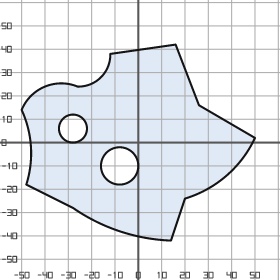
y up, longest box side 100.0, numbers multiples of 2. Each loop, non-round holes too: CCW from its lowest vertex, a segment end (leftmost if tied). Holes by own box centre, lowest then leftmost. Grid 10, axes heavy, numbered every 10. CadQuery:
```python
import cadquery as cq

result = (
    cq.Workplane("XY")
    .moveTo(14.0, -42.0)
    .lineTo(20.0, -24.0)
    .threePointArc((38.0, -14.0), (50.0, 2.0))
    .lineTo(26.0, 16.0)
    .lineTo(16.0, 42.0)
    .lineTo(-12.0, 38.0)
    .threePointArc((-16.0, 28.0), (-26.0, 24.0))
    .threePointArc((-40.0, 24.0), (-50.0, 14.0))
    .threePointArc((-46.0, -2.0), (-48.0, -18.0))
    .lineTo(-28.0, -28.0)
    .threePointArc((-8.0, -38.0), (14.0, -42.0))
    .close()
    .moveTo(-8.0, -10.0)
    .circle(8.0)
    .moveTo(-28.0, 6.0)
    .circle(6.0)
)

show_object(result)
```